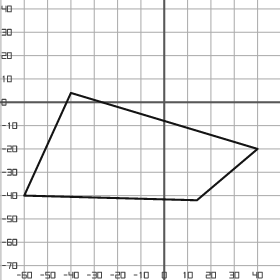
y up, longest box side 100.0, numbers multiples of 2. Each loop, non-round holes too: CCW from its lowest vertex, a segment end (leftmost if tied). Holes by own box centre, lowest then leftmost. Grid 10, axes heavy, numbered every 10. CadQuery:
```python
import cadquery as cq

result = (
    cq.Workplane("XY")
    .moveTo(14.0, -42.0)
    .lineTo(40.0, -20.0)
    .lineTo(-40.0, 4.0)
    .lineTo(-60.0, -40.0)
    .close()
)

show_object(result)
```